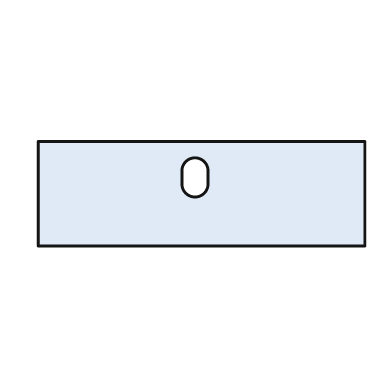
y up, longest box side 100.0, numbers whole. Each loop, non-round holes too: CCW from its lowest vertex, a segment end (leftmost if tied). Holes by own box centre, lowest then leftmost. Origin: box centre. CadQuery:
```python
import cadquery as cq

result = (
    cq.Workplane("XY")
    .moveTo(-50.0, -16.0)
    .lineTo(50.0, -16.0)
    .lineTo(50.0, 16.0)
    .lineTo(-50.0, 16.0)
    .close()
    .moveTo(-6.0, 3.0)
    .threePointArc((-2.0, -1.0), (2.0, 3.0))
    .lineTo(2.0, 7.0)
    .threePointArc((-2.0, 11.0), (-6.0, 7.0))
    .close()
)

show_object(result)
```